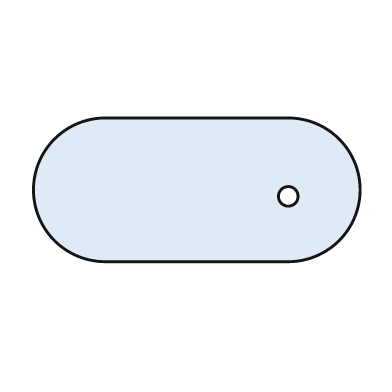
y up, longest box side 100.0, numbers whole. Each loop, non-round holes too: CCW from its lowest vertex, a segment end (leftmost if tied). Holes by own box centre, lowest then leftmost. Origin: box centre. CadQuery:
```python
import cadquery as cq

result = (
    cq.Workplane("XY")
    .moveTo(-28.0, -22.0)
    .lineTo(28.0, -22.0)
    .threePointArc((50.0, 0.0), (28.0, 22.0))
    .lineTo(-28.0, 22.0)
    .threePointArc((-50.0, 0.0), (-28.0, -22.0))
    .close()
    .moveTo(28.0, -2.0)
    .circle(3.0)
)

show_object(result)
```